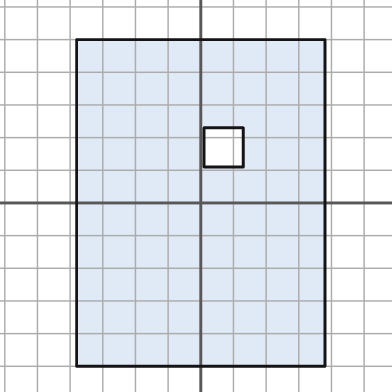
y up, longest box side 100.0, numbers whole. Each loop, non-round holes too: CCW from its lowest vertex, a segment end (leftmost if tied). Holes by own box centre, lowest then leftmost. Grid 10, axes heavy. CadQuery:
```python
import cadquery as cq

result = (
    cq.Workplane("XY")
    .moveTo(-38.0, -50.0)
    .lineTo(38.0, -50.0)
    .lineTo(38.0, 50.0)
    .lineTo(-38.0, 50.0)
    .close()
    .moveTo(1.0, 11.0)
    .lineTo(13.0, 11.0)
    .lineTo(13.0, 23.0)
    .lineTo(1.0, 23.0)
    .close()
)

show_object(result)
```